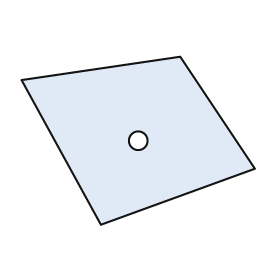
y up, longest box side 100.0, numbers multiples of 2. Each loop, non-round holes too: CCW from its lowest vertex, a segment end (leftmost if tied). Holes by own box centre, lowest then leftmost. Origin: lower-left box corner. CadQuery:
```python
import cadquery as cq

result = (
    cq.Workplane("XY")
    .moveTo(34.0, 0.0)
    .lineTo(100.0, 24.0)
    .lineTo(68.0, 72.0)
    .lineTo(0.0, 62.0)
    .close()
    .moveTo(50.0, 36.0)
    .circle(4.0)
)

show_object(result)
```